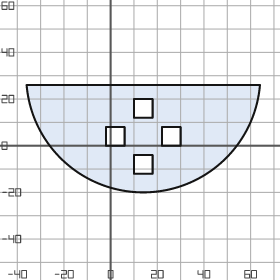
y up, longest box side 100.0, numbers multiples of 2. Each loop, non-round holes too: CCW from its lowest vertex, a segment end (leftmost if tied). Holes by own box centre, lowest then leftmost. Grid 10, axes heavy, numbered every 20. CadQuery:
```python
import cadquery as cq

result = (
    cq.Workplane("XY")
    .moveTo(-36.0, 26.0)
    .threePointArc((14.0, -20.0), (64.0, 26.0))
    .close()
    .moveTo(10.0, -12.0)
    .lineTo(18.0, -12.0)
    .lineTo(18.0, -4.0)
    .lineTo(10.0, -4.0)
    .close()
    .moveTo(-2.0, 0.0)
    .lineTo(6.0, 0.0)
    .lineTo(6.0, 8.0)
    .lineTo(-2.0, 8.0)
    .close()
    .moveTo(22.0, 0.0)
    .lineTo(30.0, 0.0)
    .lineTo(30.0, 8.0)
    .lineTo(22.0, 8.0)
    .close()
    .moveTo(10.0, 12.0)
    .lineTo(18.0, 12.0)
    .lineTo(18.0, 20.0)
    .lineTo(10.0, 20.0)
    .close()
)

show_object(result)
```